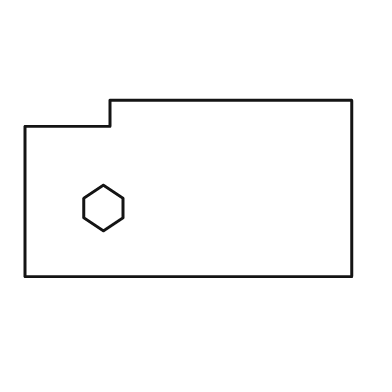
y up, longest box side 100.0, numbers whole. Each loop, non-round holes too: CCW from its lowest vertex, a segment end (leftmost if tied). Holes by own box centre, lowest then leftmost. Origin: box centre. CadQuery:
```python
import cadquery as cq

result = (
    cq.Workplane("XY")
    .moveTo(-50.0, -27.0)
    .lineTo(50.0, -27.0)
    .lineTo(50.0, 27.0)
    .lineTo(-24.0, 27.0)
    .lineTo(-24.0, 19.0)
    .lineTo(-50.0, 19.0)
    .close()
    .moveTo(-26.0, -13.0)
    .lineTo(-20.0, -9.0)
    .lineTo(-20.0, -3.0)
    .lineTo(-26.0, 1.0)
    .lineTo(-32.0, -3.0)
    .lineTo(-32.0, -9.0)
    .close()
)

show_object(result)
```